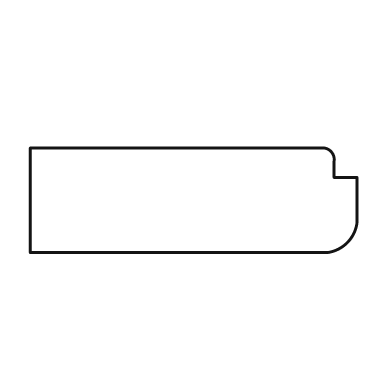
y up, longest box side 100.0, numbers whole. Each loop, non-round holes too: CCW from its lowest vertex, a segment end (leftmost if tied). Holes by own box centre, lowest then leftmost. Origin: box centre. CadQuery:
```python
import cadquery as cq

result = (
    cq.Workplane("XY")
    .moveTo(-50.0, -16.0)
    .lineTo(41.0, -16.0)
    .threePointArc((47.0, -13.0), (50.0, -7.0))
    .lineTo(50.0, 7.0)
    .lineTo(43.0, 7.0)
    .lineTo(43.0, 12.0)
    .threePointArc((42.0, 15.0), (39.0, 16.0))
    .lineTo(-50.0, 16.0)
    .close()
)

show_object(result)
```